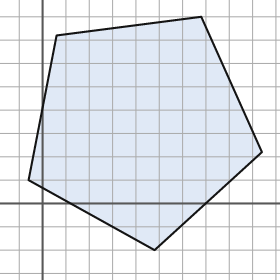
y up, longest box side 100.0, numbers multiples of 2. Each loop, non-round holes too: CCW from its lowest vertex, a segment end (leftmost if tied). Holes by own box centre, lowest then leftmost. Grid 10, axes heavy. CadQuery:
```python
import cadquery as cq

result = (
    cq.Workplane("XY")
    .moveTo(48.0, -20.0)
    .lineTo(94.0, 22.0)
    .lineTo(68.0, 80.0)
    .lineTo(6.0, 72.0)
    .lineTo(-6.0, 10.0)
    .close()
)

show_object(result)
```